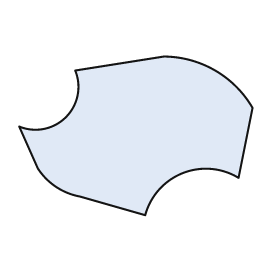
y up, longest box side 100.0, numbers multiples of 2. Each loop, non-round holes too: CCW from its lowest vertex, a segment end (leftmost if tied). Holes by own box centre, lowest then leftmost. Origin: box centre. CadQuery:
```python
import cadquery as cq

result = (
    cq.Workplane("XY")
    .moveTo(4.0, -34.0)
    .threePointArc((20.0, -16.0), (44.0, -18.0))
    .lineTo(50.0, 12.0)
    .threePointArc((34.0, 28.0), (12.0, 34.0))
    .lineTo(-26.0, 28.0)
    .threePointArc((-30.0, 8.0), (-50.0, 4.0))
    .lineTo(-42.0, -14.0)
    .threePointArc((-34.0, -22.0), (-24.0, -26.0))
    .close()
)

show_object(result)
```